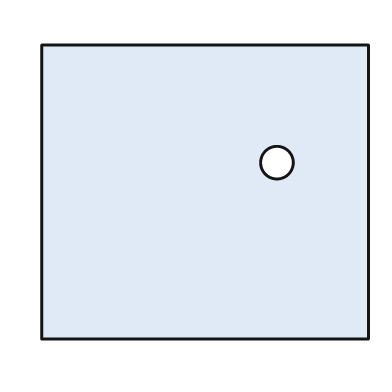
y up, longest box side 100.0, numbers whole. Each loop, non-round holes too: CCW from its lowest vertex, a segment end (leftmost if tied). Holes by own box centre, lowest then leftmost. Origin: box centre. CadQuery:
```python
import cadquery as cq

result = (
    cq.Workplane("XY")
    .moveTo(-50.0, -45.0)
    .lineTo(50.0, -45.0)
    .lineTo(50.0, 45.0)
    .lineTo(-50.0, 45.0)
    .close()
    .moveTo(22.0, 9.0)
    .circle(5.0)
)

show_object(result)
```